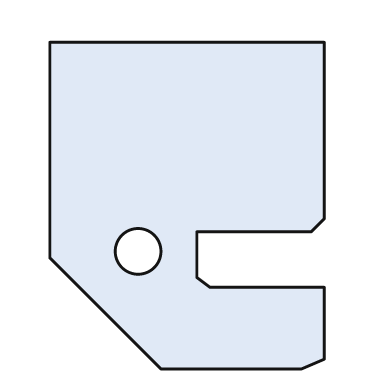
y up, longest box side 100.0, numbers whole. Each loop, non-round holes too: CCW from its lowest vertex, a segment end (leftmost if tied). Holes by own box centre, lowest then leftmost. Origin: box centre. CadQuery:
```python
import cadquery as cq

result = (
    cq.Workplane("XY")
    .moveTo(-8.0, -50.0)
    .lineTo(35.0, -50.0)
    .lineTo(42.0, -47.0)
    .lineTo(42.0, -25.0)
    .lineTo(7.0, -25.0)
    .lineTo(3.0, -22.0)
    .lineTo(3.0, -8.0)
    .lineTo(38.0, -8.0)
    .lineTo(42.0, -4.0)
    .lineTo(42.0, 50.0)
    .lineTo(-42.0, 50.0)
    .lineTo(-42.0, -16.0)
    .close()
    .moveTo(-15.0, -14.0)
    .circle(7.0)
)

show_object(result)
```